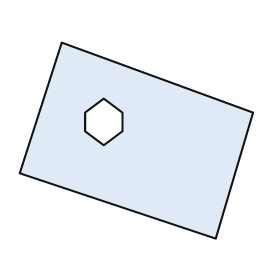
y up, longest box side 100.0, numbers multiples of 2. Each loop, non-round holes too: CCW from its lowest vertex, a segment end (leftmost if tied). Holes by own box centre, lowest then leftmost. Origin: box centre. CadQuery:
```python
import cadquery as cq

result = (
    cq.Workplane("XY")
    .moveTo(34.0, -42.0)
    .lineTo(50.0, 12.0)
    .lineTo(-32.0, 42.0)
    .lineTo(-50.0, -14.0)
    .close()
    .moveTo(-14.0, -2.0)
    .lineTo(-6.0, 4.0)
    .lineTo(-6.0, 12.0)
    .lineTo(-14.0, 18.0)
    .lineTo(-22.0, 12.0)
    .lineTo(-22.0, 4.0)
    .close()
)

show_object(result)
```